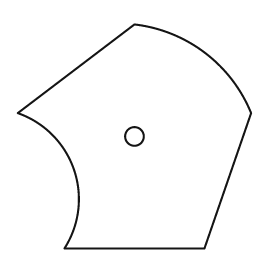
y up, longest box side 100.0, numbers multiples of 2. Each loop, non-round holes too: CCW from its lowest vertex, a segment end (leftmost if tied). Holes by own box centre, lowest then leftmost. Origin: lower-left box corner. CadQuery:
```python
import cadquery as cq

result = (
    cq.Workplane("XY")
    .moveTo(20.0, 0.0)
    .lineTo(80.0, 0.0)
    .lineTo(100.0, 58.0)
    .threePointArc((80.0, 84.0), (50.0, 96.0))
    .lineTo(0.0, 58.0)
    .threePointArc((24.0, 34.0), (20.0, 0.0))
    .close()
    .moveTo(50.0, 48.0)
    .circle(4.0)
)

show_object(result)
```